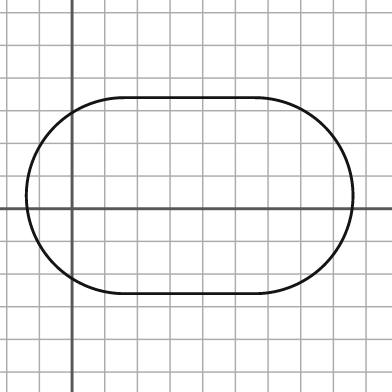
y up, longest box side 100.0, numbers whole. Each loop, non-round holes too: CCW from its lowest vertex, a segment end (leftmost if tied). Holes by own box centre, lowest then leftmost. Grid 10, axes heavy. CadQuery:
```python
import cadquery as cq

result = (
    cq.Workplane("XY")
    .moveTo(16.0, -26.0)
    .lineTo(56.0, -26.0)
    .threePointArc((86.0, 4.0), (56.0, 34.0))
    .lineTo(16.0, 34.0)
    .threePointArc((-14.0, 4.0), (16.0, -26.0))
    .close()
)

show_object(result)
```